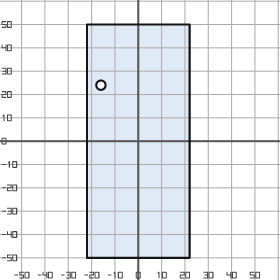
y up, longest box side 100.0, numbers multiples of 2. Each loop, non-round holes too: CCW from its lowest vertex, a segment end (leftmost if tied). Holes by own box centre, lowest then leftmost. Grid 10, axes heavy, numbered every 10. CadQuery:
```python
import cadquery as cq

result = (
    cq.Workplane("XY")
    .moveTo(-22.0, -50.0)
    .lineTo(22.0, -50.0)
    .lineTo(22.0, 50.0)
    .lineTo(-22.0, 50.0)
    .close()
    .moveTo(-16.0, 24.0)
    .circle(2.0)
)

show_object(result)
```